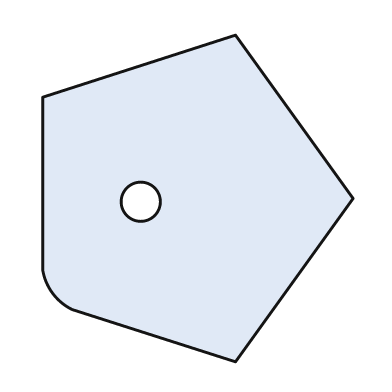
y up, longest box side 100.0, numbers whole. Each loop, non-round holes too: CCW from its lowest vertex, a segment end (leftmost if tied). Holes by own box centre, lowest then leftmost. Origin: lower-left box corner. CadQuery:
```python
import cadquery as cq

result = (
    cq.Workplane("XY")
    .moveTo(59.0, 0.0)
    .lineTo(95.0, 50.0)
    .lineTo(59.0, 100.0)
    .lineTo(0.0, 81.0)
    .lineTo(0.0, 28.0)
    .threePointArc((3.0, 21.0), (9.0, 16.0))
    .close()
    .moveTo(30.0, 49.0)
    .circle(6.0)
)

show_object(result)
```